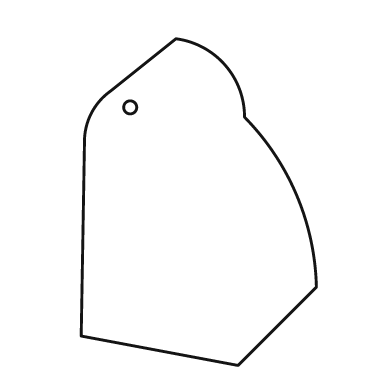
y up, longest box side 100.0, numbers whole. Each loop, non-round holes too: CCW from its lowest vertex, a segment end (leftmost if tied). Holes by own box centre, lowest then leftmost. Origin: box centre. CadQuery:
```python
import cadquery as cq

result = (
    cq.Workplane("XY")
    .moveTo(12.0, -50.0)
    .lineTo(36.0, -26.0)
    .threePointArc((30.0, 2.0), (14.0, 26.0))
    .threePointArc((8.0, 42.0), (-7.0, 50.0))
    .lineTo(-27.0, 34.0)
    .threePointArc((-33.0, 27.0), (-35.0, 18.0))
    .lineTo(-36.0, -41.0)
    .close()
    .moveTo(-21.0, 29.0)
    .circle(2.0)
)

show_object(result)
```